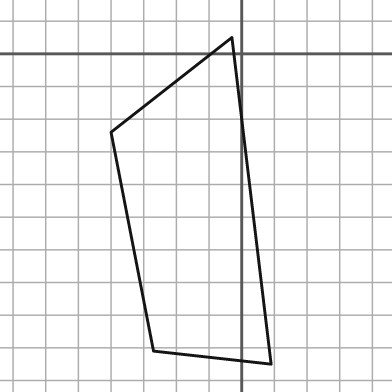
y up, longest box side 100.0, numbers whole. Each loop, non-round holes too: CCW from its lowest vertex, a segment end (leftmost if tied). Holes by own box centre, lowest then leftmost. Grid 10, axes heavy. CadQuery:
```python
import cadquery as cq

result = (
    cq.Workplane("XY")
    .moveTo(9.0, -95.0)
    .lineTo(-3.0, 5.0)
    .lineTo(-40.0, -24.0)
    .lineTo(-27.0, -91.0)
    .close()
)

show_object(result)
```